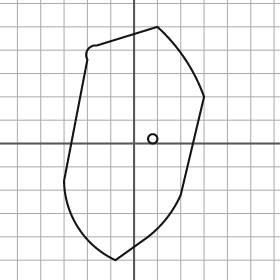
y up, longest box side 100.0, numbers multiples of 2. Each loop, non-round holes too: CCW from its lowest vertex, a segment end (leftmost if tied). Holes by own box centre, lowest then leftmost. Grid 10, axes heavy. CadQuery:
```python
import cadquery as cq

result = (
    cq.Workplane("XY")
    .moveTo(-8.0, -50.0)
    .lineTo(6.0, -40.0)
    .threePointArc((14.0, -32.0), (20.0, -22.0))
    .lineTo(30.0, 20.0)
    .threePointArc((22.0, 36.0), (10.0, 50.0))
    .lineTo(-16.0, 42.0)
    .threePointArc((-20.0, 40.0), (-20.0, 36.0))
    .lineTo(-30.0, -16.0)
    .threePointArc((-24.0, -36.0), (-8.0, -50.0))
    .close()
    .moveTo(8.0, 2.0)
    .circle(2.0)
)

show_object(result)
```